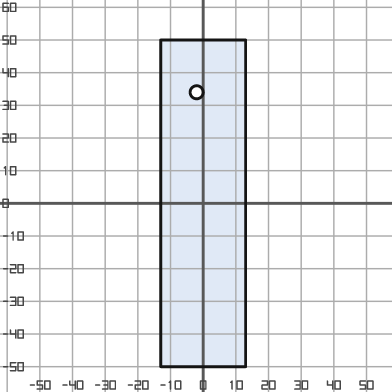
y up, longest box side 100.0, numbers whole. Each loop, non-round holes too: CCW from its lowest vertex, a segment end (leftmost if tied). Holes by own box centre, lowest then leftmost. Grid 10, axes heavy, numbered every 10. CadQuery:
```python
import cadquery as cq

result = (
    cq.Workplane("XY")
    .moveTo(-13.0, -50.0)
    .lineTo(13.0, -50.0)
    .lineTo(13.0, 50.0)
    .lineTo(-13.0, 50.0)
    .close()
    .moveTo(-2.0, 34.0)
    .circle(2.0)
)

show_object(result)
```